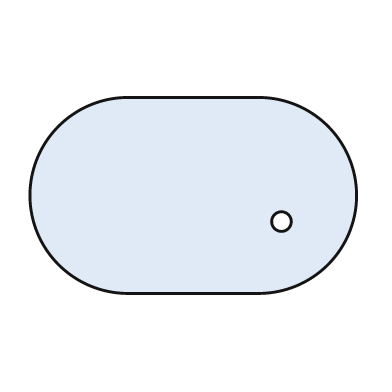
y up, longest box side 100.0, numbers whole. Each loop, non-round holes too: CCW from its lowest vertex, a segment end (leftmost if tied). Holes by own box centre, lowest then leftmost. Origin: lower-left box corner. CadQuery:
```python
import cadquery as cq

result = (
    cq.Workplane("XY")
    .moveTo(30.0, 0.0)
    .lineTo(70.0, 0.0)
    .threePointArc((100.0, 30.0), (70.0, 60.0))
    .lineTo(30.0, 60.0)
    .threePointArc((0.0, 30.0), (30.0, 0.0))
    .close()
    .moveTo(77.0, 22.0)
    .circle(3.0)
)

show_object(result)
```